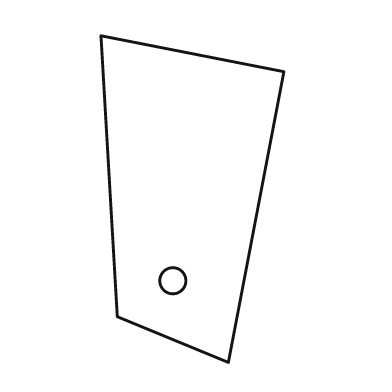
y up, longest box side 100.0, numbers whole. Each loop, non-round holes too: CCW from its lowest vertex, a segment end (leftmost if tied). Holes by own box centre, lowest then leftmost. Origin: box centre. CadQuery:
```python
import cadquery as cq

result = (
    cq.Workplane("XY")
    .moveTo(11.0, -50.0)
    .lineTo(28.0, 39.0)
    .lineTo(-28.0, 50.0)
    .lineTo(-23.0, -36.0)
    .close()
    .moveTo(-6.0, -25.0)
    .circle(4.0)
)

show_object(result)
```